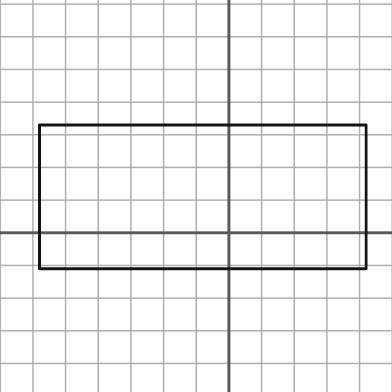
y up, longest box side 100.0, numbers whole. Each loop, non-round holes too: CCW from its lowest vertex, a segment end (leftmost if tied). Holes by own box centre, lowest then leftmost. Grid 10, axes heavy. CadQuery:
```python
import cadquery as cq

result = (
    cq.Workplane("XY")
    .moveTo(-58.0, -11.0)
    .lineTo(42.0, -11.0)
    .lineTo(42.0, 33.0)
    .lineTo(-58.0, 33.0)
    .close()
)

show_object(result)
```